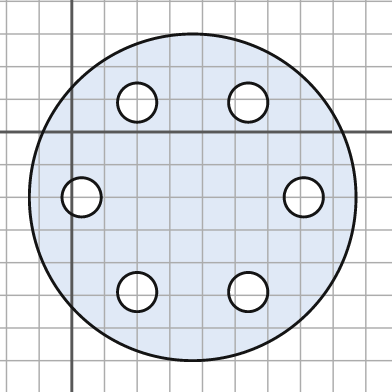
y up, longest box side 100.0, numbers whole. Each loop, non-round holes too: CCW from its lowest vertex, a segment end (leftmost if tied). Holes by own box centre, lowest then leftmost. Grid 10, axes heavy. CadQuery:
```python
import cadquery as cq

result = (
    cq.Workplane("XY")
    .moveTo(37.0, -20.0)
    .circle(50.0)
    .moveTo(20.0, -49.0)
    .circle(6.0)
    .moveTo(54.0, -49.0)
    .circle(6.0)
    .moveTo(3.0, -20.0)
    .circle(6.0)
    .moveTo(71.0, -20.0)
    .circle(6.0)
    .moveTo(20.0, 9.0)
    .circle(6.0)
    .moveTo(54.0, 9.0)
    .circle(6.0)
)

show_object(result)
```